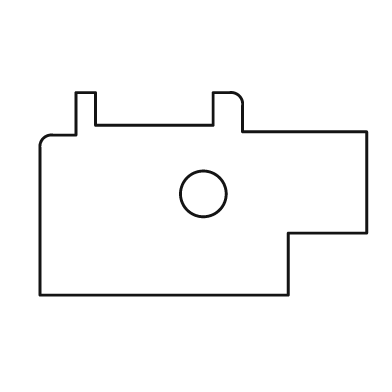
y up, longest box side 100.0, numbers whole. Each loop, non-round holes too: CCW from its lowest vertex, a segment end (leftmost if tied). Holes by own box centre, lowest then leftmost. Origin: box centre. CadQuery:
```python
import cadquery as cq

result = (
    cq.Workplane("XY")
    .moveTo(-50.0, -31.0)
    .lineTo(26.0, -31.0)
    .lineTo(26.0, -12.0)
    .lineTo(50.0, -12.0)
    .lineTo(50.0, 19.0)
    .lineTo(12.0, 19.0)
    .lineTo(12.0, 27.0)
    .threePointArc((11.0, 30.0), (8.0, 31.0))
    .lineTo(3.0, 31.0)
    .lineTo(3.0, 21.0)
    .lineTo(-33.0, 21.0)
    .lineTo(-33.0, 31.0)
    .lineTo(-39.0, 31.0)
    .lineTo(-39.0, 18.0)
    .lineTo(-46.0, 18.0)
    .threePointArc((-49.0, 17.0), (-50.0, 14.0))
    .close()
    .moveTo(0.0, 0.0)
    .circle(7.0)
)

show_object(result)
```